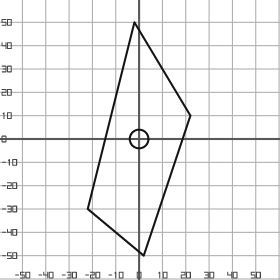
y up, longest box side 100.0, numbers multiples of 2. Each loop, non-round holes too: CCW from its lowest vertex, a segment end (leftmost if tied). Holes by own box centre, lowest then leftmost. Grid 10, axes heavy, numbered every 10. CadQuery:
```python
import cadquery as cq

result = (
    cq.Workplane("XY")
    .moveTo(2.0, -50.0)
    .lineTo(22.0, 10.0)
    .lineTo(-2.0, 50.0)
    .lineTo(-22.0, -30.0)
    .close()
    .moveTo(0.0, 0.0)
    .circle(4.0)
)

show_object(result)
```